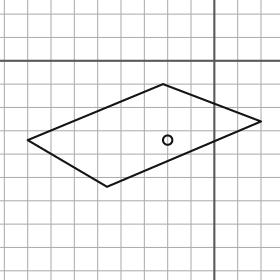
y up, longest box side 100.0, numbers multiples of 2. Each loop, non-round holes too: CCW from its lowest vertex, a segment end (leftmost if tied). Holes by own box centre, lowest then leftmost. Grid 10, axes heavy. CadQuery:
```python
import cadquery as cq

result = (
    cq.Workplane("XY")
    .moveTo(-46.0, -54.0)
    .lineTo(20.0, -26.0)
    .lineTo(-22.0, -10.0)
    .lineTo(-80.0, -34.0)
    .close()
    .moveTo(-20.0, -34.0)
    .circle(2.0)
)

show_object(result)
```